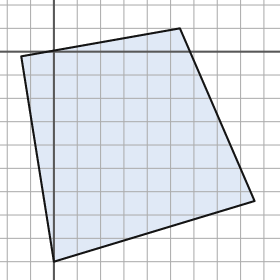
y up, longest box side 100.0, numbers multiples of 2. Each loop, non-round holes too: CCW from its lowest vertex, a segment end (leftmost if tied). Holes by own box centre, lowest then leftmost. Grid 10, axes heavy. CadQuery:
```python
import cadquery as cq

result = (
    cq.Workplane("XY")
    .moveTo(0.0, -90.0)
    .lineTo(86.0, -64.0)
    .lineTo(54.0, 10.0)
    .lineTo(-14.0, -2.0)
    .close()
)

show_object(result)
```